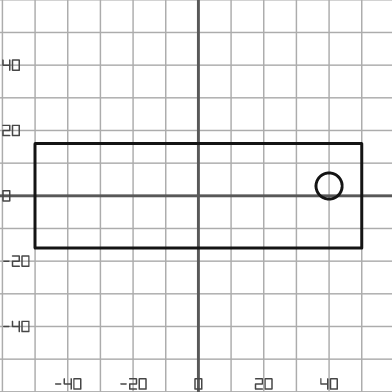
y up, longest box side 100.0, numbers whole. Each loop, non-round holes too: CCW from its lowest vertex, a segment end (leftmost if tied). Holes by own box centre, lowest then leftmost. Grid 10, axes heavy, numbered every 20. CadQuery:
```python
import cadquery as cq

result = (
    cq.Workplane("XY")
    .moveTo(-50.0, -16.0)
    .lineTo(50.0, -16.0)
    .lineTo(50.0, 16.0)
    .lineTo(-50.0, 16.0)
    .close()
    .moveTo(40.0, 3.0)
    .circle(4.0)
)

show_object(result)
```